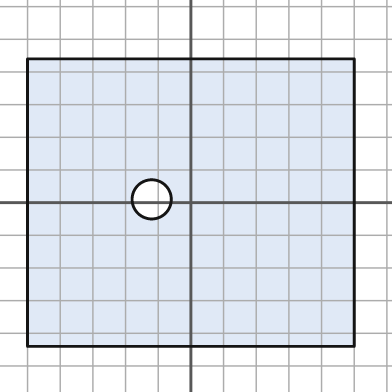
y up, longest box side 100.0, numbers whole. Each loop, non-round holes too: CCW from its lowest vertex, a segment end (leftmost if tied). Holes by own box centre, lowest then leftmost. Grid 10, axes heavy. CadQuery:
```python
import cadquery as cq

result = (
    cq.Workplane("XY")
    .moveTo(-50.0, -44.0)
    .lineTo(50.0, -44.0)
    .lineTo(50.0, 44.0)
    .lineTo(-50.0, 44.0)
    .close()
    .moveTo(-12.0, 1.0)
    .circle(6.0)
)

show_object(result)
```